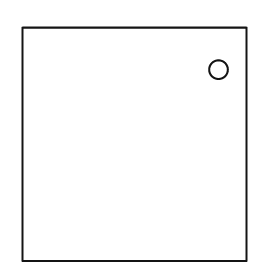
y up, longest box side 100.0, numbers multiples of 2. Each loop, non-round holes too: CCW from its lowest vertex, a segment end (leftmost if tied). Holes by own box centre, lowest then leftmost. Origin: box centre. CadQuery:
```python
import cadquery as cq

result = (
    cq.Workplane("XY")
    .moveTo(-48.0, -50.0)
    .lineTo(48.0, -50.0)
    .lineTo(48.0, 50.0)
    .lineTo(-48.0, 50.0)
    .close()
    .moveTo(36.0, 32.0)
    .circle(4.0)
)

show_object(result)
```